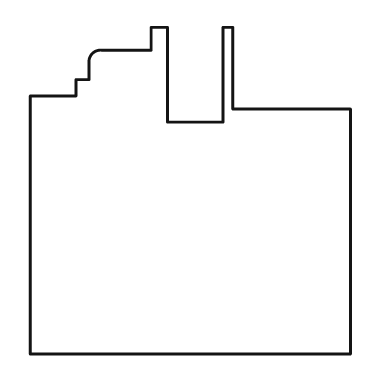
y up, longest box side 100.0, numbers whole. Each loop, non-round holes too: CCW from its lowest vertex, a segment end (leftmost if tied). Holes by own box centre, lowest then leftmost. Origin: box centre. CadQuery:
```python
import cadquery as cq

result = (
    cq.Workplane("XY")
    .moveTo(-49.0, -50.0)
    .lineTo(49.0, -50.0)
    .lineTo(49.0, 25.0)
    .lineTo(13.0, 25.0)
    .lineTo(13.0, 50.0)
    .lineTo(10.0, 50.0)
    .lineTo(10.0, 21.0)
    .lineTo(-7.0, 21.0)
    .lineTo(-7.0, 50.0)
    .lineTo(-12.0, 50.0)
    .lineTo(-12.0, 43.0)
    .lineTo(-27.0, 43.0)
    .threePointArc((-30.0, 42.0), (-31.0, 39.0))
    .lineTo(-31.0, 34.0)
    .lineTo(-35.0, 34.0)
    .lineTo(-35.0, 29.0)
    .lineTo(-49.0, 29.0)
    .close()
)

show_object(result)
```